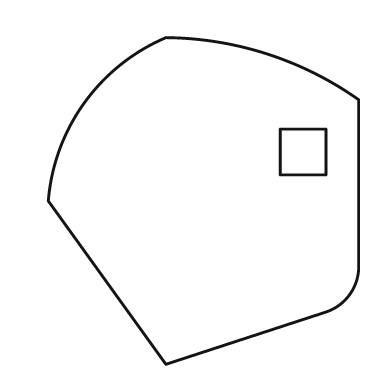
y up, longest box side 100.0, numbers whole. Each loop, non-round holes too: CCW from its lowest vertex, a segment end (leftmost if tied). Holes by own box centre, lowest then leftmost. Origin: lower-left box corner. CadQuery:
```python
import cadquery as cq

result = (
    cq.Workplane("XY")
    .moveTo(36.0, 0.0)
    .lineTo(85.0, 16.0)
    .threePointArc((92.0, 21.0), (95.0, 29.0))
    .lineTo(95.0, 81.0)
    .threePointArc((67.0, 95.0), (36.0, 100.0))
    .threePointArc((11.0, 80.0), (0.0, 50.0))
    .close()
    .moveTo(71.0, 58.0)
    .lineTo(85.0, 58.0)
    .lineTo(85.0, 72.0)
    .lineTo(71.0, 72.0)
    .close()
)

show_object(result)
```